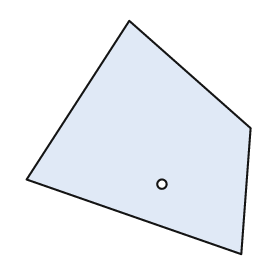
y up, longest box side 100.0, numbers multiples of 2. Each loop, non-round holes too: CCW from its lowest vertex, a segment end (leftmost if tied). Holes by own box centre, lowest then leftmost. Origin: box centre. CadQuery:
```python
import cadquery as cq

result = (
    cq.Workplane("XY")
    .moveTo(44.0, -50.0)
    .lineTo(48.0, 4.0)
    .lineTo(-4.0, 50.0)
    .lineTo(-48.0, -18.0)
    .close()
    .moveTo(10.0, -20.0)
    .circle(2.0)
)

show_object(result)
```